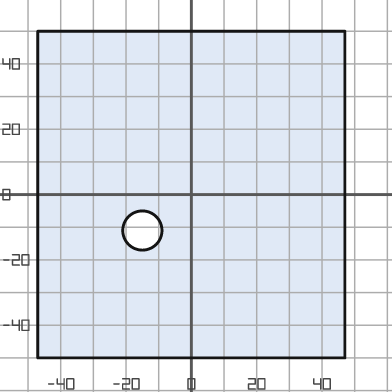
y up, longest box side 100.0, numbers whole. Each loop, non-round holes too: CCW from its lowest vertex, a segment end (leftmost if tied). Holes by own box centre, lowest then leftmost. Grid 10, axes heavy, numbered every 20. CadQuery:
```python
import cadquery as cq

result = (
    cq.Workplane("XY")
    .moveTo(-47.0, -50.0)
    .lineTo(47.0, -50.0)
    .lineTo(47.0, 50.0)
    .lineTo(-47.0, 50.0)
    .close()
    .moveTo(-15.0, -11.0)
    .circle(6.0)
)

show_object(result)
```